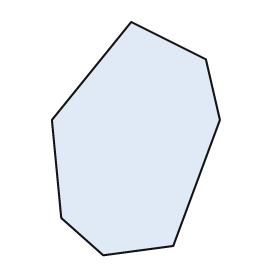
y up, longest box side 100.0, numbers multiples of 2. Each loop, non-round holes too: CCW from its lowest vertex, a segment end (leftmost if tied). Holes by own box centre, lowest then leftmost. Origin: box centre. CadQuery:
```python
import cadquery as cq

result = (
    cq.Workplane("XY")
    .moveTo(-14.0, -50.0)
    .lineTo(16.0, -46.0)
    .lineTo(36.0, 8.0)
    .lineTo(30.0, 34.0)
    .lineTo(-2.0, 50.0)
    .lineTo(-36.0, 8.0)
    .lineTo(-32.0, -34.0)
    .close()
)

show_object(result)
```